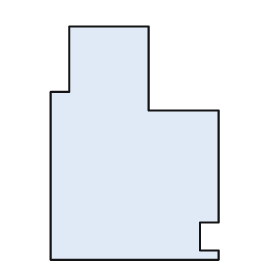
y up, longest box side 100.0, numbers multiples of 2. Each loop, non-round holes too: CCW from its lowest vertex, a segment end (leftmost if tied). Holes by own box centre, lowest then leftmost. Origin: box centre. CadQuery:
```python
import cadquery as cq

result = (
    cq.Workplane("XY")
    .moveTo(-36.0, -50.0)
    .lineTo(36.0, -50.0)
    .lineTo(36.0, -46.0)
    .lineTo(28.0, -46.0)
    .lineTo(28.0, -34.0)
    .lineTo(36.0, -34.0)
    .lineTo(36.0, 14.0)
    .lineTo(6.0, 14.0)
    .lineTo(6.0, 50.0)
    .lineTo(-28.0, 50.0)
    .lineTo(-28.0, 22.0)
    .lineTo(-36.0, 22.0)
    .close()
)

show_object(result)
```